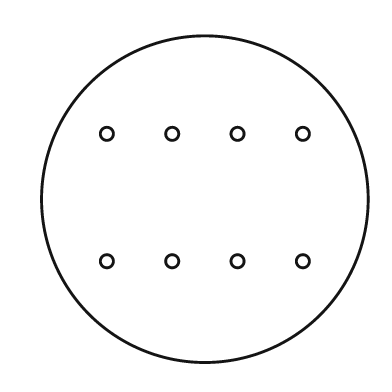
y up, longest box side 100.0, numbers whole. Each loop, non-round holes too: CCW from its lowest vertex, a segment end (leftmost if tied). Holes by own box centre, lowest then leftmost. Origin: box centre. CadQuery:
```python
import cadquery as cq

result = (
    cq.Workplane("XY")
    .moveTo(0.0, 0.0)
    .circle(50.0)
    .moveTo(-30.0, -19.0)
    .circle(2.0)
    .moveTo(-10.0, -19.0)
    .circle(2.0)
    .moveTo(10.0, -19.0)
    .circle(2.0)
    .moveTo(30.0, -19.0)
    .circle(2.0)
    .moveTo(-30.0, 20.0)
    .circle(2.0)
    .moveTo(-10.0, 20.0)
    .circle(2.0)
    .moveTo(10.0, 20.0)
    .circle(2.0)
    .moveTo(30.0, 20.0)
    .circle(2.0)
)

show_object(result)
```